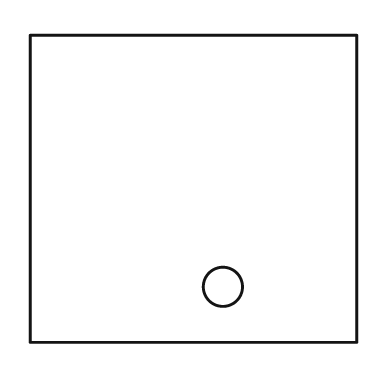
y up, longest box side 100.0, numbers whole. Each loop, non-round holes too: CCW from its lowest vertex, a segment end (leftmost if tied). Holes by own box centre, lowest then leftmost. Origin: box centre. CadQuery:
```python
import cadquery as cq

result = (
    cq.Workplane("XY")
    .moveTo(-50.0, -47.0)
    .lineTo(50.0, -47.0)
    .lineTo(50.0, 47.0)
    .lineTo(-50.0, 47.0)
    .close()
    .moveTo(9.0, -30.0)
    .circle(6.0)
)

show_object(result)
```